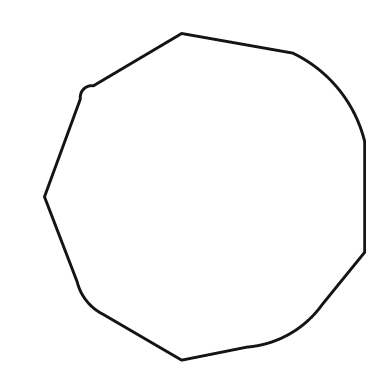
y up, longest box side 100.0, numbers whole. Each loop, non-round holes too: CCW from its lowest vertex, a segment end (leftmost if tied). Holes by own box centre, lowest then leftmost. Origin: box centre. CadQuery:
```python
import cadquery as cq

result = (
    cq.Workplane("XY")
    .moveTo(-7.0, -50.0)
    .lineTo(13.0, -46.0)
    .threePointArc((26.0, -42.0), (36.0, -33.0))
    .lineTo(49.0, -17.0)
    .lineTo(49.0, 17.0)
    .threePointArc((41.0, 33.0), (27.0, 44.0))
    .lineTo(-7.0, 50.0)
    .lineTo(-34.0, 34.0)
    .threePointArc((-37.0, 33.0), (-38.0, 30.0))
    .lineTo(-49.0, 0.0)
    .lineTo(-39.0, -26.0)
    .threePointArc((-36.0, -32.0), (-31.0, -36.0))
    .close()
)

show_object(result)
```